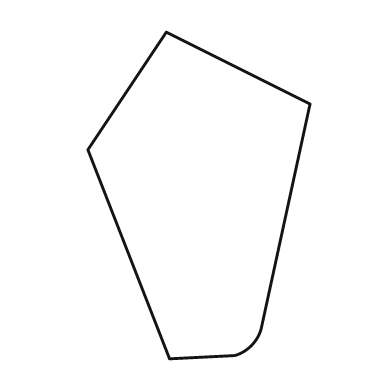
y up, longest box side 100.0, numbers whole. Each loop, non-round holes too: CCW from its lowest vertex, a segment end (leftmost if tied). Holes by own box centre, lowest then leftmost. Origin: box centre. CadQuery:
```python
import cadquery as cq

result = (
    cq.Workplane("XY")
    .moveTo(-9.0, -50.0)
    .lineTo(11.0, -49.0)
    .threePointArc((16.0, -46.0), (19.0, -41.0))
    .lineTo(34.0, 28.0)
    .lineTo(-10.0, 50.0)
    .lineTo(-34.0, 14.0)
    .close()
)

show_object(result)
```